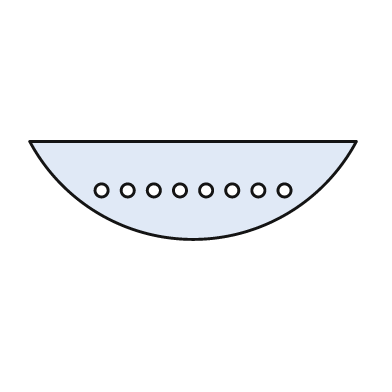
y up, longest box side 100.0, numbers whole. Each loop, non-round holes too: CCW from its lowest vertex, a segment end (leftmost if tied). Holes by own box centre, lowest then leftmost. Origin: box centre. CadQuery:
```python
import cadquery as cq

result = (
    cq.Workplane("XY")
    .moveTo(-50.0, 15.0)
    .threePointArc((0.0, -15.0), (50.0, 15.0))
    .close()
    .moveTo(-28.0, 0.0)
    .circle(2.0)
    .moveTo(-20.0, 0.0)
    .circle(2.0)
    .moveTo(-12.0, 0.0)
    .circle(2.0)
    .moveTo(-4.0, 0.0)
    .circle(2.0)
    .moveTo(4.0, 0.0)
    .circle(2.0)
    .moveTo(12.0, 0.0)
    .circle(2.0)
    .moveTo(20.0, 0.0)
    .circle(2.0)
    .moveTo(28.0, 0.0)
    .circle(2.0)
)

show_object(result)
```